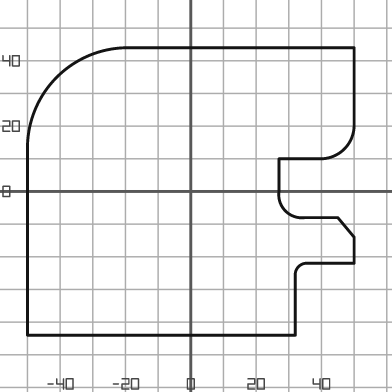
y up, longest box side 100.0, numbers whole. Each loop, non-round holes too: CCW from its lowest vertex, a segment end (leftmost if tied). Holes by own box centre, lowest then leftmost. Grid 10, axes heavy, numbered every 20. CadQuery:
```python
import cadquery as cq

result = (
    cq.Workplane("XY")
    .moveTo(-50.0, -44.0)
    .lineTo(32.0, -44.0)
    .lineTo(32.0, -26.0)
    .threePointArc((33.0, -23.0), (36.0, -22.0))
    .lineTo(50.0, -22.0)
    .lineTo(50.0, -14.0)
    .lineTo(45.0, -8.0)
    .lineTo(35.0, -8.0)
    .threePointArc((29.0, -6.0), (27.0, 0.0))
    .lineTo(27.0, 10.0)
    .lineTo(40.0, 10.0)
    .threePointArc((47.0, 13.0), (50.0, 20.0))
    .lineTo(50.0, 44.0)
    .lineTo(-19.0, 44.0)
    .threePointArc((-41.0, 35.0), (-50.0, 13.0))
    .close()
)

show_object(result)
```